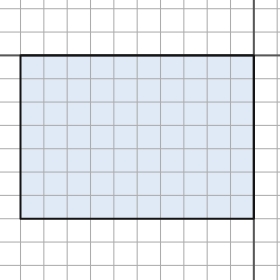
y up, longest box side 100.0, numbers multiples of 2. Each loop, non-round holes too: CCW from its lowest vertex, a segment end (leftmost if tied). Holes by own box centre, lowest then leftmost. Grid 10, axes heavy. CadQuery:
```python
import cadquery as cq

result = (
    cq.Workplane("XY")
    .moveTo(-100.0, -70.0)
    .lineTo(0.0, -70.0)
    .lineTo(0.0, 0.0)
    .lineTo(-100.0, 0.0)
    .close()
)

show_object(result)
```